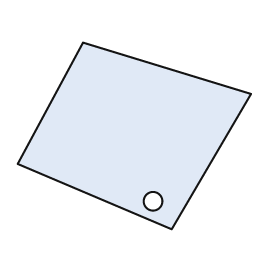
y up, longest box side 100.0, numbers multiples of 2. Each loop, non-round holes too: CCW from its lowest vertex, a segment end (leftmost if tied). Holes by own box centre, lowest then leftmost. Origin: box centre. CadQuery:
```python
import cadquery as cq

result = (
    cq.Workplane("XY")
    .moveTo(16.0, -40.0)
    .lineTo(50.0, 18.0)
    .lineTo(-22.0, 40.0)
    .lineTo(-50.0, -12.0)
    .close()
    .moveTo(8.0, -28.0)
    .circle(4.0)
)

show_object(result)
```